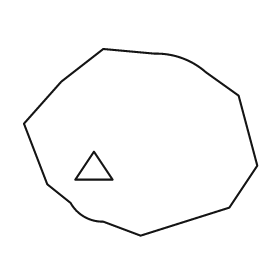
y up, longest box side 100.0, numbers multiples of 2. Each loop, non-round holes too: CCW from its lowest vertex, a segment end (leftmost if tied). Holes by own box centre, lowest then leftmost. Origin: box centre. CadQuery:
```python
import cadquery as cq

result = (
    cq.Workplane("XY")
    .moveTo(0.0, -40.0)
    .lineTo(38.0, -28.0)
    .lineTo(50.0, -10.0)
    .lineTo(42.0, 20.0)
    .lineTo(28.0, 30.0)
    .threePointArc((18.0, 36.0), (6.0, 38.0))
    .lineTo(-16.0, 40.0)
    .lineTo(-34.0, 26.0)
    .lineTo(-50.0, 8.0)
    .lineTo(-40.0, -18.0)
    .lineTo(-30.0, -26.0)
    .threePointArc((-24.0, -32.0), (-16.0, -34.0))
    .close()
    .moveTo(-28.0, -16.0)
    .lineTo(-12.0, -16.0)
    .lineTo(-20.0, -4.0)
    .close()
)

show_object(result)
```